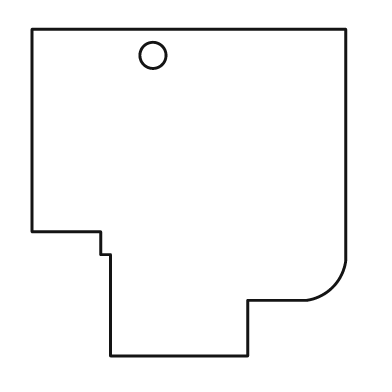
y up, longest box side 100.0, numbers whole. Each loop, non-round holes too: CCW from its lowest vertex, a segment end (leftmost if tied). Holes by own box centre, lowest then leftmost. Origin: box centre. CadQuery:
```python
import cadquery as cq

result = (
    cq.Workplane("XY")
    .moveTo(-24.0, -50.0)
    .lineTo(18.0, -50.0)
    .lineTo(18.0, -33.0)
    .lineTo(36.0, -33.0)
    .threePointArc((44.0, -29.0), (48.0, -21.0))
    .lineTo(48.0, 50.0)
    .lineTo(-48.0, 50.0)
    .lineTo(-48.0, -12.0)
    .lineTo(-27.0, -12.0)
    .lineTo(-27.0, -19.0)
    .lineTo(-24.0, -19.0)
    .close()
    .moveTo(-11.0, 42.0)
    .circle(4.0)
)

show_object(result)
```